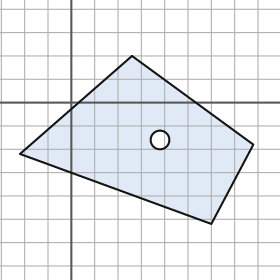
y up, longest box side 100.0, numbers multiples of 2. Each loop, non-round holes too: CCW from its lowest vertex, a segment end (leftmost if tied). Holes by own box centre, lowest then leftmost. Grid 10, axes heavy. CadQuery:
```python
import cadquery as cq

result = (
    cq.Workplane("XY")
    .moveTo(60.0, -52.0)
    .lineTo(78.0, -18.0)
    .lineTo(26.0, 20.0)
    .lineTo(-22.0, -22.0)
    .close()
    .moveTo(38.0, -16.0)
    .circle(4.0)
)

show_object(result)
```